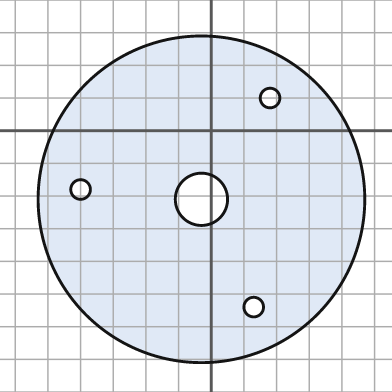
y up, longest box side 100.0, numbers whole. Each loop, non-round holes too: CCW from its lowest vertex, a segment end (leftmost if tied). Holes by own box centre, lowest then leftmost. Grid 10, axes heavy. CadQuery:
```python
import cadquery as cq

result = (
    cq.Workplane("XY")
    .moveTo(-3.0, -21.0)
    .circle(50.0)
    .moveTo(13.0, -54.0)
    .circle(3.0)
    .moveTo(-3.0, -21.0)
    .circle(8.0)
    .moveTo(-40.0, -18.0)
    .circle(3.0)
    .moveTo(18.0, 10.0)
    .circle(3.0)
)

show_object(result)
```